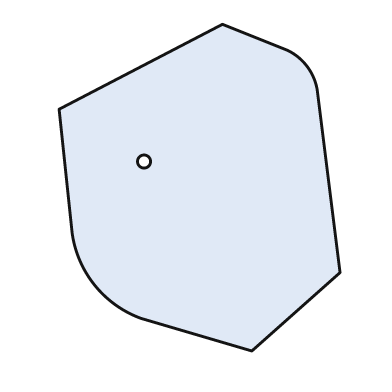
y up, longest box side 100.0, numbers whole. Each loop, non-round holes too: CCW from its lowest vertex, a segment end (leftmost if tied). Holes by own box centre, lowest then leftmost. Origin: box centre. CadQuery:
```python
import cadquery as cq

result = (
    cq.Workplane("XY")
    .moveTo(16.0, -50.0)
    .lineTo(43.0, -26.0)
    .lineTo(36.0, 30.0)
    .threePointArc((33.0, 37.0), (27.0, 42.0))
    .lineTo(7.0, 50.0)
    .lineTo(-43.0, 24.0)
    .lineTo(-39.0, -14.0)
    .threePointArc((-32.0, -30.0), (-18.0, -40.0))
    .close()
    .moveTo(-17.0, 8.0)
    .circle(2.0)
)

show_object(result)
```